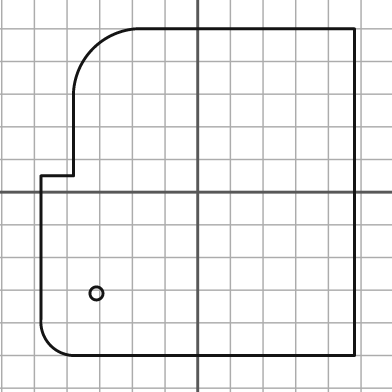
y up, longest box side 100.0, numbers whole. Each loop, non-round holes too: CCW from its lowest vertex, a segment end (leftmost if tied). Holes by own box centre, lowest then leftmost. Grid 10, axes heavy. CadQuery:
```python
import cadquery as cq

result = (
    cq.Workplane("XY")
    .moveTo(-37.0, -50.0)
    .lineTo(48.0, -50.0)
    .lineTo(48.0, 50.0)
    .lineTo(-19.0, 50.0)
    .threePointArc((-32.0, 44.0), (-38.0, 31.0))
    .lineTo(-38.0, 5.0)
    .lineTo(-48.0, 5.0)
    .lineTo(-48.0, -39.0)
    .threePointArc((-45.0, -47.0), (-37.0, -50.0))
    .close()
    .moveTo(-31.0, -31.0)
    .circle(2.0)
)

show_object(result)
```